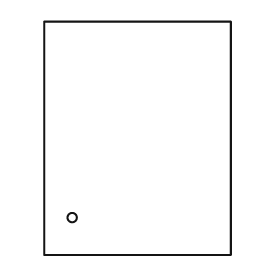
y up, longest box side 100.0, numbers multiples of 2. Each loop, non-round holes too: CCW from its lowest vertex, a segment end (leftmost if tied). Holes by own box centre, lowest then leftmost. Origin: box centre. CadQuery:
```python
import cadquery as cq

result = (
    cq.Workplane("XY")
    .moveTo(-40.0, -50.0)
    .lineTo(40.0, -50.0)
    .lineTo(40.0, 50.0)
    .lineTo(-40.0, 50.0)
    .close()
    .moveTo(-28.0, -34.0)
    .circle(2.0)
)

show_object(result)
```